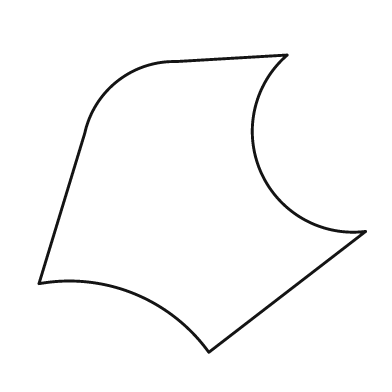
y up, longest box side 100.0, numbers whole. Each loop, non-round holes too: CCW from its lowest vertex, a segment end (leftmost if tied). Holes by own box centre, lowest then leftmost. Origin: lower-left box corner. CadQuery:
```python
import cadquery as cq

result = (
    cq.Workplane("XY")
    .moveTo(52.0, 0.0)
    .lineTo(100.0, 37.0)
    .threePointArc((68.0, 55.0), (76.0, 91.0))
    .lineTo(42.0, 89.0)
    .threePointArc((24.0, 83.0), (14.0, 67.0))
    .lineTo(0.0, 21.0)
    .threePointArc((29.0, 18.0), (52.0, 0.0))
    .close()
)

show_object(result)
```